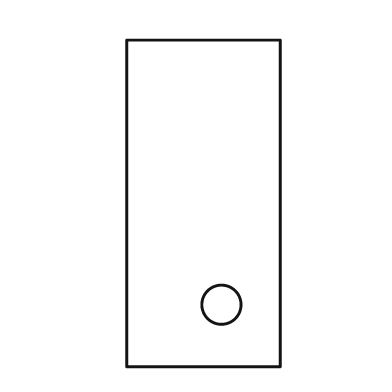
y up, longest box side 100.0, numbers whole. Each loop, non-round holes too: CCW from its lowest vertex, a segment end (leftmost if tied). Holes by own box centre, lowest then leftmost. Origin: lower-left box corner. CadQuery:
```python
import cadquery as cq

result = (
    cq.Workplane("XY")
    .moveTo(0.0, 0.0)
    .lineTo(47.0, 0.0)
    .lineTo(47.0, 100.0)
    .lineTo(0.0, 100.0)
    .close()
    .moveTo(29.0, 19.0)
    .circle(6.0)
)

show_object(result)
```